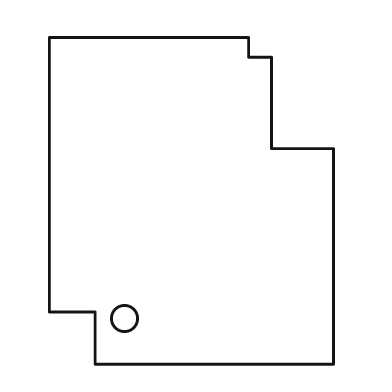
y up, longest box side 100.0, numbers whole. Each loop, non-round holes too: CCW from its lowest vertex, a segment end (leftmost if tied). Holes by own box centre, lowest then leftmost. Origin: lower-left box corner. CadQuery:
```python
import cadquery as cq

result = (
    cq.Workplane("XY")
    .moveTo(14.0, 0.0)
    .lineTo(87.0, 0.0)
    .lineTo(87.0, 66.0)
    .lineTo(68.0, 66.0)
    .lineTo(68.0, 94.0)
    .lineTo(61.0, 94.0)
    .lineTo(61.0, 100.0)
    .lineTo(0.0, 100.0)
    .lineTo(0.0, 16.0)
    .lineTo(14.0, 16.0)
    .close()
    .moveTo(23.0, 14.0)
    .circle(4.0)
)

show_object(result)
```